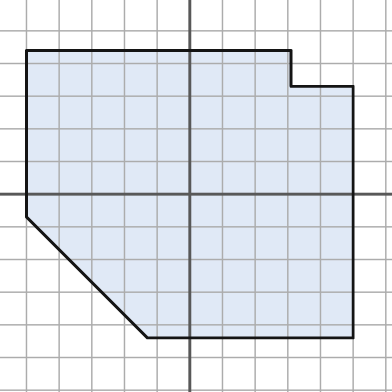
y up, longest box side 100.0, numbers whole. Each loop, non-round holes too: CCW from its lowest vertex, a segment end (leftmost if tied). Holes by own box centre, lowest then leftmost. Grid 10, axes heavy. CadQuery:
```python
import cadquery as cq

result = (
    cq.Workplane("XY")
    .moveTo(-13.0, -44.0)
    .lineTo(50.0, -44.0)
    .lineTo(50.0, 33.0)
    .lineTo(31.0, 33.0)
    .lineTo(31.0, 44.0)
    .lineTo(-50.0, 44.0)
    .lineTo(-50.0, -7.0)
    .close()
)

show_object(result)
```